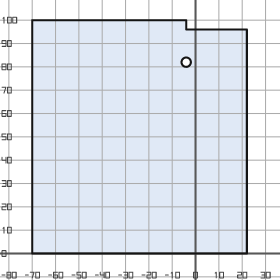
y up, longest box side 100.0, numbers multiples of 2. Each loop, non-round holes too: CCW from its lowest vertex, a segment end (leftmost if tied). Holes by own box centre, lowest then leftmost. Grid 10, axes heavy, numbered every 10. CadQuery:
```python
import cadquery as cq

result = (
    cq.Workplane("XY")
    .moveTo(-70.0, 0.0)
    .lineTo(22.0, 0.0)
    .lineTo(22.0, 96.0)
    .lineTo(-4.0, 96.0)
    .lineTo(-4.0, 100.0)
    .lineTo(-70.0, 100.0)
    .close()
    .moveTo(-4.0, 82.0)
    .circle(2.0)
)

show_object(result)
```